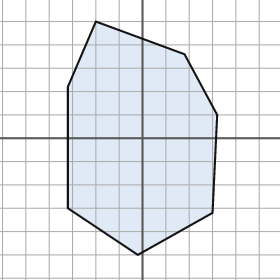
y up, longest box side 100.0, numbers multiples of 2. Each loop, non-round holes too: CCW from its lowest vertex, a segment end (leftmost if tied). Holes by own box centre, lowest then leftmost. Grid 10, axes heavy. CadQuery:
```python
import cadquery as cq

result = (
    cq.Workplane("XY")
    .moveTo(-2.0, -50.0)
    .lineTo(30.0, -32.0)
    .lineTo(32.0, 10.0)
    .lineTo(18.0, 36.0)
    .lineTo(-20.0, 50.0)
    .lineTo(-32.0, 22.0)
    .lineTo(-32.0, -30.0)
    .close()
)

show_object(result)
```